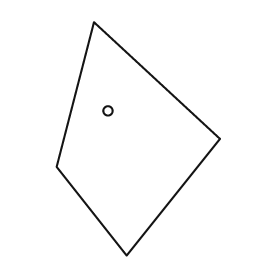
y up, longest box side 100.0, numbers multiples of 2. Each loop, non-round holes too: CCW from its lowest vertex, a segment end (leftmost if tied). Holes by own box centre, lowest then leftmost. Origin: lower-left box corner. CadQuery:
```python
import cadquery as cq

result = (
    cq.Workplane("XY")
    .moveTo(30.0, 0.0)
    .lineTo(70.0, 50.0)
    .lineTo(16.0, 100.0)
    .lineTo(0.0, 38.0)
    .close()
    .moveTo(22.0, 62.0)
    .circle(2.0)
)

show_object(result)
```